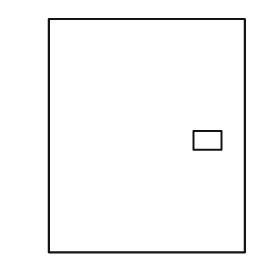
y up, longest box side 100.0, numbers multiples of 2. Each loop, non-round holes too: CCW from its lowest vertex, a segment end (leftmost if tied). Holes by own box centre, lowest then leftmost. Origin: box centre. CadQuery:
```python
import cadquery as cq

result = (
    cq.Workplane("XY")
    .moveTo(-42.0, -50.0)
    .lineTo(42.0, -50.0)
    .lineTo(42.0, 50.0)
    .lineTo(-42.0, 50.0)
    .close()
    .moveTo(20.0, -6.0)
    .lineTo(32.0, -6.0)
    .lineTo(32.0, 2.0)
    .lineTo(20.0, 2.0)
    .close()
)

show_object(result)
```